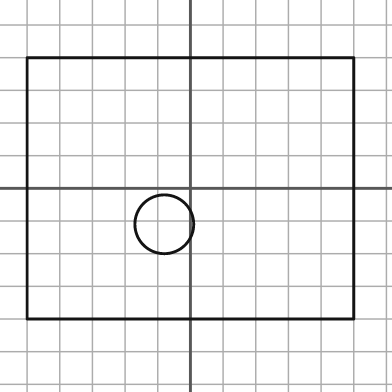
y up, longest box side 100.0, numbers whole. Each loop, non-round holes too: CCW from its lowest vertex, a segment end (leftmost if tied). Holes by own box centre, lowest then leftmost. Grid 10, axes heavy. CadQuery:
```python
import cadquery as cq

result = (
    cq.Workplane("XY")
    .moveTo(-50.0, -40.0)
    .lineTo(50.0, -40.0)
    .lineTo(50.0, 40.0)
    .lineTo(-50.0, 40.0)
    .close()
    .moveTo(-8.0, -11.0)
    .circle(9.0)
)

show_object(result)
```